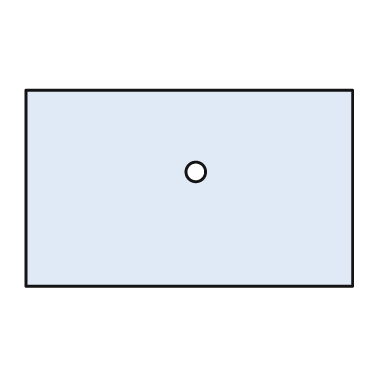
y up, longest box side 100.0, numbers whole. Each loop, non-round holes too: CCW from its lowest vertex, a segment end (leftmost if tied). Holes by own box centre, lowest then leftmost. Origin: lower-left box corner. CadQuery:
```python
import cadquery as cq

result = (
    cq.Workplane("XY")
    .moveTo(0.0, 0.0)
    .lineTo(100.0, 0.0)
    .lineTo(100.0, 60.0)
    .lineTo(0.0, 60.0)
    .close()
    .moveTo(52.0, 35.0)
    .circle(3.0)
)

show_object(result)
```